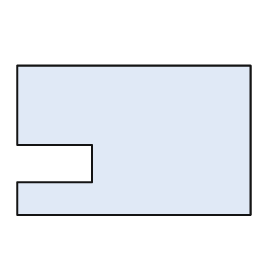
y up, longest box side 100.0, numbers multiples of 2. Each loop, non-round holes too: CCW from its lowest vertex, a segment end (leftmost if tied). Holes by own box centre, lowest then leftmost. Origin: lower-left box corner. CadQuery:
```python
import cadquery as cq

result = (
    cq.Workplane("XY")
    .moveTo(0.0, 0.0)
    .lineTo(100.0, 0.0)
    .lineTo(100.0, 64.0)
    .lineTo(0.0, 64.0)
    .lineTo(0.0, 30.0)
    .lineTo(32.0, 30.0)
    .lineTo(32.0, 14.0)
    .lineTo(0.0, 14.0)
    .close()
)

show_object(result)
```